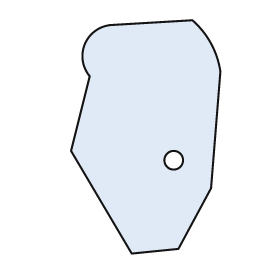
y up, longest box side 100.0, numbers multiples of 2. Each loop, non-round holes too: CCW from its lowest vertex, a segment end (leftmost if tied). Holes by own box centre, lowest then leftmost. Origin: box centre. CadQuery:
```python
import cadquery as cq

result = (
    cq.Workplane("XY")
    .moveTo(-6.0, -50.0)
    .lineTo(14.0, -48.0)
    .lineTo(28.0, -22.0)
    .lineTo(32.0, 28.0)
    .threePointArc((28.0, 40.0), (20.0, 50.0))
    .lineTo(-14.0, 48.0)
    .threePointArc((-26.0, 40.0), (-24.0, 26.0))
    .lineTo(-32.0, -6.0)
    .close()
    .moveTo(12.0, -10.0)
    .circle(4.0)
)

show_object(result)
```